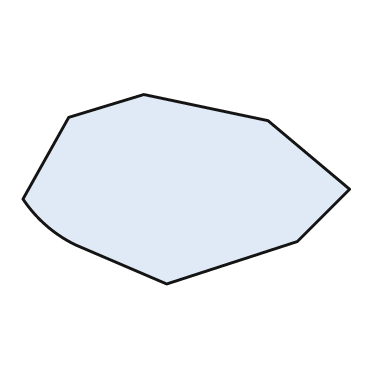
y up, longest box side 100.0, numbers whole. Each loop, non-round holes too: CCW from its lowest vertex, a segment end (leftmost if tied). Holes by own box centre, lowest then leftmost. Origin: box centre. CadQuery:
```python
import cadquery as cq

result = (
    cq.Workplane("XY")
    .moveTo(-6.0, -29.0)
    .lineTo(34.0, -16.0)
    .lineTo(50.0, 0.0)
    .lineTo(25.0, 21.0)
    .lineTo(-13.0, 29.0)
    .lineTo(-36.0, 22.0)
    .lineTo(-50.0, -3.0)
    .threePointArc((-43.0, -11.0), (-34.0, -17.0))
    .close()
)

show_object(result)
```